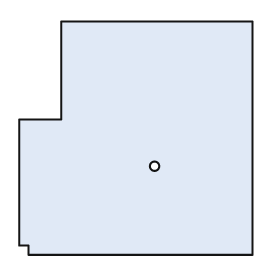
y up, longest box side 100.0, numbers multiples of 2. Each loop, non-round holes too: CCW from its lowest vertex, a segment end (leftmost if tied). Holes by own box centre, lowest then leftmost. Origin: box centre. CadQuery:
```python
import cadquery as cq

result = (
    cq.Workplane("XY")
    .moveTo(-46.0, -50.0)
    .lineTo(50.0, -50.0)
    .lineTo(50.0, 50.0)
    .lineTo(-32.0, 50.0)
    .lineTo(-32.0, 8.0)
    .lineTo(-50.0, 8.0)
    .lineTo(-50.0, -46.0)
    .lineTo(-46.0, -46.0)
    .close()
    .moveTo(8.0, -12.0)
    .circle(2.0)
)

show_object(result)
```